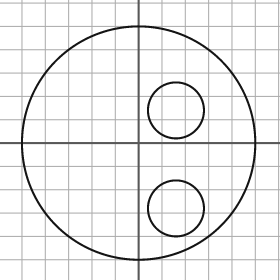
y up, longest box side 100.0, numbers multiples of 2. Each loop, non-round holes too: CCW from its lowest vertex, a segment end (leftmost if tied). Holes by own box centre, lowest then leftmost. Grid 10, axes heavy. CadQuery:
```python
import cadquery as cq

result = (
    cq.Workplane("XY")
    .moveTo(0.0, 0.0)
    .circle(50.0)
    .moveTo(16.0, -28.0)
    .circle(12.0)
    .moveTo(16.0, 14.0)
    .circle(12.0)
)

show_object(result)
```